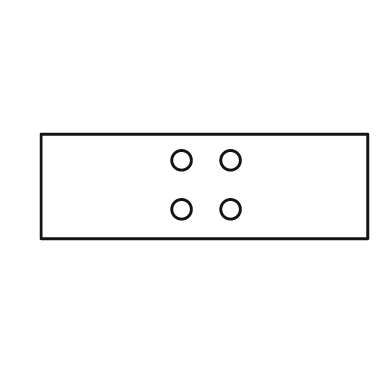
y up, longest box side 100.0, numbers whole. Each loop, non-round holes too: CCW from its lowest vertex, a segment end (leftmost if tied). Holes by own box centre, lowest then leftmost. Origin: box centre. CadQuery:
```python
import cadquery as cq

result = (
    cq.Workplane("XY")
    .moveTo(-50.0, -16.0)
    .lineTo(50.0, -16.0)
    .lineTo(50.0, 16.0)
    .lineTo(-50.0, 16.0)
    .close()
    .moveTo(-7.0, -7.0)
    .circle(3.0)
    .moveTo(8.0, -7.0)
    .circle(3.0)
    .moveTo(-7.0, 8.0)
    .circle(3.0)
    .moveTo(8.0, 8.0)
    .circle(3.0)
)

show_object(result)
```